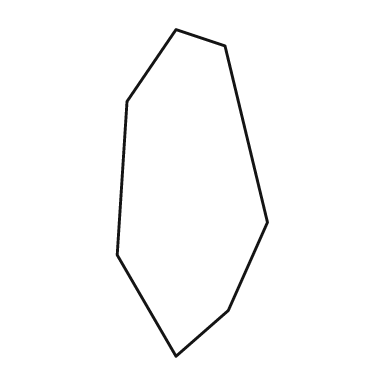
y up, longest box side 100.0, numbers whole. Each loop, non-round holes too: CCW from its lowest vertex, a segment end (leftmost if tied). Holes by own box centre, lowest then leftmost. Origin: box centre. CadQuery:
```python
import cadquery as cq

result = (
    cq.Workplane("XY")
    .moveTo(-5.0, -50.0)
    .lineTo(11.0, -36.0)
    .lineTo(23.0, -9.0)
    .lineTo(10.0, 45.0)
    .lineTo(-5.0, 50.0)
    .lineTo(-20.0, 28.0)
    .lineTo(-23.0, -19.0)
    .close()
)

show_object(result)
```